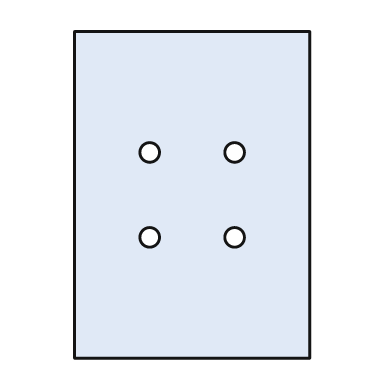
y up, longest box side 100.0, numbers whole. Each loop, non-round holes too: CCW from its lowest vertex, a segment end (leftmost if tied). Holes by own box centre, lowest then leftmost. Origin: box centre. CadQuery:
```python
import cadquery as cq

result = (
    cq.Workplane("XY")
    .moveTo(-36.0, -50.0)
    .lineTo(36.0, -50.0)
    .lineTo(36.0, 50.0)
    .lineTo(-36.0, 50.0)
    .close()
    .moveTo(-13.0, -13.0)
    .circle(3.0)
    .moveTo(13.0, -13.0)
    .circle(3.0)
    .moveTo(-13.0, 13.0)
    .circle(3.0)
    .moveTo(13.0, 13.0)
    .circle(3.0)
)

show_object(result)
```